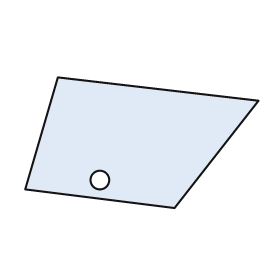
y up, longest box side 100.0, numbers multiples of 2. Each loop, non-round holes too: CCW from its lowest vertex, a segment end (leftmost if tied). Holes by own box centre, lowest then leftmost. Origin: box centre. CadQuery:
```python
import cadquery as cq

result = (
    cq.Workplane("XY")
    .moveTo(14.0, -28.0)
    .lineTo(50.0, 18.0)
    .lineTo(-36.0, 28.0)
    .lineTo(-50.0, -20.0)
    .close()
    .moveTo(-18.0, -16.0)
    .circle(4.0)
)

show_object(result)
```